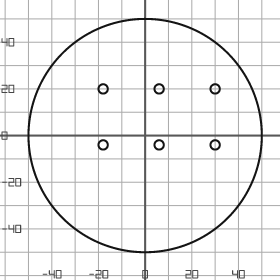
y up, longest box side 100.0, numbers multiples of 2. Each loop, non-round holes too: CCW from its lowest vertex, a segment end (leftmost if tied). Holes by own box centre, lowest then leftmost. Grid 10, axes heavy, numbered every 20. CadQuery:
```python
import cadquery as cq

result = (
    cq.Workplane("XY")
    .moveTo(0.0, 0.0)
    .circle(50.0)
    .moveTo(-18.0, -4.0)
    .circle(2.0)
    .moveTo(6.0, -4.0)
    .circle(2.0)
    .moveTo(30.0, -4.0)
    .circle(2.0)
    .moveTo(-18.0, 20.0)
    .circle(2.0)
    .moveTo(6.0, 20.0)
    .circle(2.0)
    .moveTo(30.0, 20.0)
    .circle(2.0)
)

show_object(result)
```